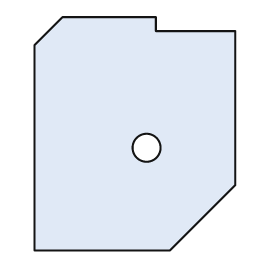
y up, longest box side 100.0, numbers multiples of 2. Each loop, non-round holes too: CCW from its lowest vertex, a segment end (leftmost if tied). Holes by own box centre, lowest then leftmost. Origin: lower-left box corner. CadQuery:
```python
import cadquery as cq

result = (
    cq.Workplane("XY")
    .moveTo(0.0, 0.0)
    .lineTo(58.0, 0.0)
    .lineTo(86.0, 28.0)
    .lineTo(86.0, 94.0)
    .lineTo(52.0, 94.0)
    .lineTo(52.0, 100.0)
    .lineTo(12.0, 100.0)
    .lineTo(0.0, 88.0)
    .close()
    .moveTo(48.0, 44.0)
    .circle(6.0)
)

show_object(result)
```